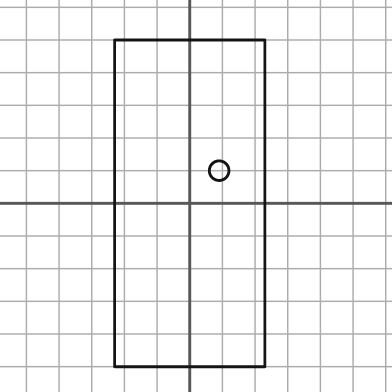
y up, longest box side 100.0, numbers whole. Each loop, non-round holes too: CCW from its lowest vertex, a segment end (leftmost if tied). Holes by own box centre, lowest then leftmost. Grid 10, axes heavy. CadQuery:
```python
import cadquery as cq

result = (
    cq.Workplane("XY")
    .moveTo(-23.0, -50.0)
    .lineTo(23.0, -50.0)
    .lineTo(23.0, 50.0)
    .lineTo(-23.0, 50.0)
    .close()
    .moveTo(9.0, 10.0)
    .circle(3.0)
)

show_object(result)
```